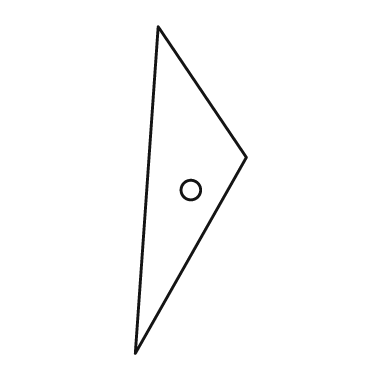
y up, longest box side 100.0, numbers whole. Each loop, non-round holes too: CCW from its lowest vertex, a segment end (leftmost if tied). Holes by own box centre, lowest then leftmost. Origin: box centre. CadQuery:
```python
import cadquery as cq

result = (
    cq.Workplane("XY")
    .moveTo(-17.0, -50.0)
    .lineTo(17.0, 10.0)
    .lineTo(-10.0, 50.0)
    .close()
    .moveTo(0.0, 0.0)
    .circle(3.0)
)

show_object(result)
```